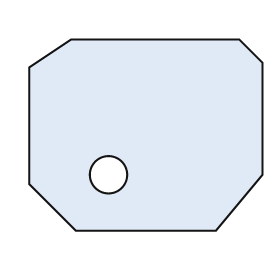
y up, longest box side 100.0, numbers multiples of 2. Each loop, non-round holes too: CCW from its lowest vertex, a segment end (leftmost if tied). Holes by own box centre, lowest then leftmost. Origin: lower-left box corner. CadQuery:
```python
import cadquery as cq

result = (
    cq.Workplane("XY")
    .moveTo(20.0, 0.0)
    .lineTo(80.0, 0.0)
    .lineTo(100.0, 24.0)
    .lineTo(100.0, 72.0)
    .lineTo(90.0, 82.0)
    .lineTo(18.0, 82.0)
    .lineTo(0.0, 70.0)
    .lineTo(0.0, 20.0)
    .close()
    .moveTo(34.0, 24.0)
    .circle(8.0)
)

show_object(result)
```